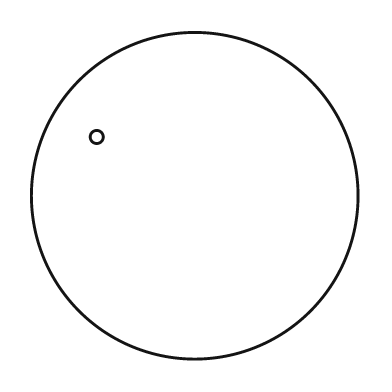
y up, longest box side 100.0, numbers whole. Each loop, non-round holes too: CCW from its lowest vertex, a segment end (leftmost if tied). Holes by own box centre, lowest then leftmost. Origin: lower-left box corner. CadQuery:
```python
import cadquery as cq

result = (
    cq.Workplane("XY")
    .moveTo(50.0, 50.0)
    .circle(50.0)
    .moveTo(20.0, 68.0)
    .circle(2.0)
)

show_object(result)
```